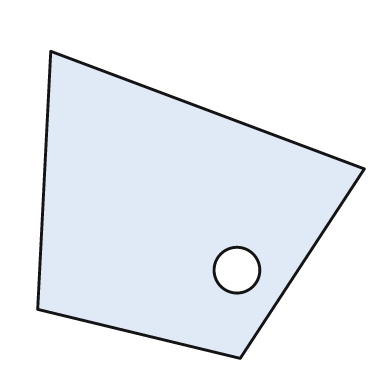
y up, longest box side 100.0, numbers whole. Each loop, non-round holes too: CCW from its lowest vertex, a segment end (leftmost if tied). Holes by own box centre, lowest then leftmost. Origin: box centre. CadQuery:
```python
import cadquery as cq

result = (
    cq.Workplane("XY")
    .moveTo(12.0, -47.0)
    .lineTo(50.0, 11.0)
    .lineTo(-46.0, 47.0)
    .lineTo(-50.0, -32.0)
    .close()
    .moveTo(11.0, -20.0)
    .circle(7.0)
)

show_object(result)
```